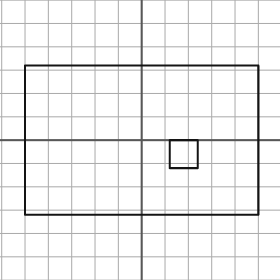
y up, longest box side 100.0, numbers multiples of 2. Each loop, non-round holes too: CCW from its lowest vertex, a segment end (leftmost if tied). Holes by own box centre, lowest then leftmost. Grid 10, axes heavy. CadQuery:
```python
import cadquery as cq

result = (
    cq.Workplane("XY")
    .moveTo(-50.0, -32.0)
    .lineTo(50.0, -32.0)
    .lineTo(50.0, 32.0)
    .lineTo(-50.0, 32.0)
    .close()
    .moveTo(12.0, -12.0)
    .lineTo(24.0, -12.0)
    .lineTo(24.0, 0.0)
    .lineTo(12.0, 0.0)
    .close()
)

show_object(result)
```